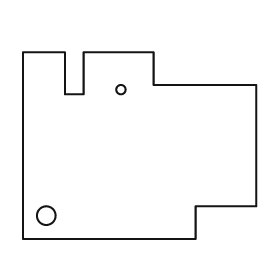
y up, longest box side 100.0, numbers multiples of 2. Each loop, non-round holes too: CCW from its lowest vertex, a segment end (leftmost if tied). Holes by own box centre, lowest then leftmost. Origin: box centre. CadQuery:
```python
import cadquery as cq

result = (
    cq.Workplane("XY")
    .moveTo(-50.0, -40.0)
    .lineTo(24.0, -40.0)
    .lineTo(24.0, -26.0)
    .lineTo(50.0, -26.0)
    .lineTo(50.0, 26.0)
    .lineTo(6.0, 26.0)
    .lineTo(6.0, 40.0)
    .lineTo(-24.0, 40.0)
    .lineTo(-24.0, 22.0)
    .lineTo(-32.0, 22.0)
    .lineTo(-32.0, 40.0)
    .lineTo(-50.0, 40.0)
    .close()
    .moveTo(-40.0, -30.0)
    .circle(4.0)
    .moveTo(-8.0, 24.0)
    .circle(2.0)
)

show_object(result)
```